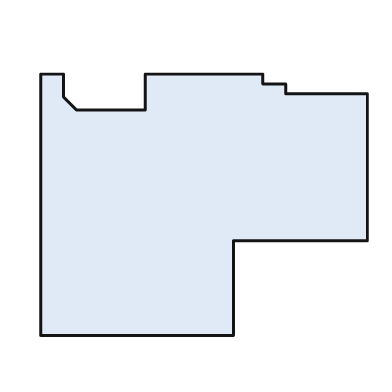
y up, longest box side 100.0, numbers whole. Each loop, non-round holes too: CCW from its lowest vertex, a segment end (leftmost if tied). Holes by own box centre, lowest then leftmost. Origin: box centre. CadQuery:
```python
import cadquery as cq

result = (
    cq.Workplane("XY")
    .moveTo(-50.0, -40.0)
    .lineTo(9.0, -40.0)
    .lineTo(9.0, -11.0)
    .lineTo(50.0, -11.0)
    .lineTo(50.0, 34.0)
    .lineTo(25.0, 34.0)
    .lineTo(25.0, 37.0)
    .lineTo(18.0, 37.0)
    .lineTo(18.0, 40.0)
    .lineTo(-18.0, 40.0)
    .lineTo(-18.0, 29.0)
    .lineTo(-39.0, 29.0)
    .lineTo(-43.0, 33.0)
    .lineTo(-43.0, 40.0)
    .lineTo(-50.0, 40.0)
    .close()
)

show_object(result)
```